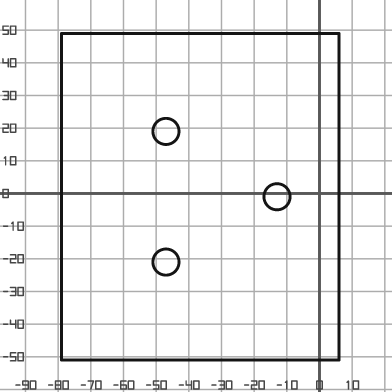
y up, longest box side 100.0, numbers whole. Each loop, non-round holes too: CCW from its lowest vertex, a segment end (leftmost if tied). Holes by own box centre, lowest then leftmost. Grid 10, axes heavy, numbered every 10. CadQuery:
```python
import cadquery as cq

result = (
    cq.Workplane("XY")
    .moveTo(-79.0, -51.0)
    .lineTo(6.0, -51.0)
    .lineTo(6.0, 49.0)
    .lineTo(-79.0, 49.0)
    .close()
    .moveTo(-47.0, -21.0)
    .circle(4.0)
    .moveTo(-13.0, -1.0)
    .circle(4.0)
    .moveTo(-47.0, 19.0)
    .circle(4.0)
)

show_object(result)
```